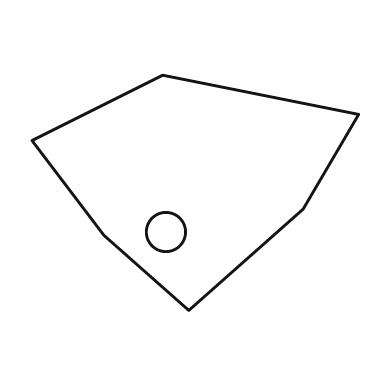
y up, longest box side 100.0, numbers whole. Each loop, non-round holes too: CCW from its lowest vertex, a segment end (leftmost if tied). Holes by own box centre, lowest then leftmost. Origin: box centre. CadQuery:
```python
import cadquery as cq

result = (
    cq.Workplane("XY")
    .moveTo(-2.0, -36.0)
    .lineTo(33.0, -5.0)
    .lineTo(50.0, 24.0)
    .lineTo(-10.0, 36.0)
    .lineTo(-50.0, 16.0)
    .lineTo(-28.0, -13.0)
    .close()
    .moveTo(-9.0, -12.0)
    .circle(6.0)
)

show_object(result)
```